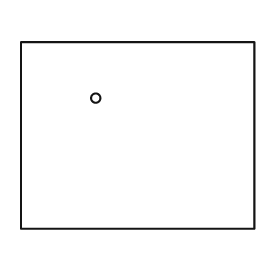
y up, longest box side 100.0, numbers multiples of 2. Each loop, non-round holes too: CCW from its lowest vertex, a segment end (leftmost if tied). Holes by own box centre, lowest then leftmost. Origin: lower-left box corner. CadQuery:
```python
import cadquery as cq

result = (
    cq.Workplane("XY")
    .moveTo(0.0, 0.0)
    .lineTo(100.0, 0.0)
    .lineTo(100.0, 80.0)
    .lineTo(0.0, 80.0)
    .close()
    .moveTo(32.0, 56.0)
    .circle(2.0)
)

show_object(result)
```